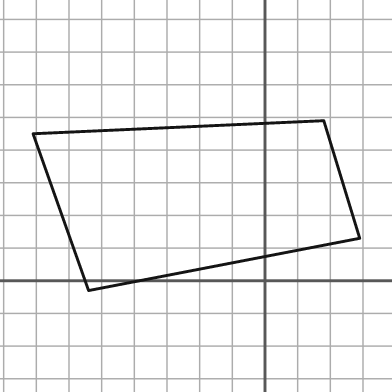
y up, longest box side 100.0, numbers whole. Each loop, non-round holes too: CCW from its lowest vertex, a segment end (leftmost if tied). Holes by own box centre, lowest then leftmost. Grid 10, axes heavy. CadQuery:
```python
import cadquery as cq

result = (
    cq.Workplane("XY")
    .moveTo(-54.0, -3.0)
    .lineTo(29.0, 13.0)
    .lineTo(18.0, 49.0)
    .lineTo(-71.0, 45.0)
    .close()
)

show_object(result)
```